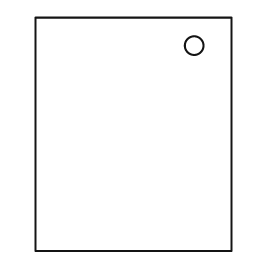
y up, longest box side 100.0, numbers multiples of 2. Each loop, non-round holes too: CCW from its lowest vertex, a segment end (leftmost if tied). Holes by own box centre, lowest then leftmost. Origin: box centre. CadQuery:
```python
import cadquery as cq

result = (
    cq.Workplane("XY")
    .moveTo(-42.0, -50.0)
    .lineTo(42.0, -50.0)
    .lineTo(42.0, 50.0)
    .lineTo(-42.0, 50.0)
    .close()
    .moveTo(26.0, 38.0)
    .circle(4.0)
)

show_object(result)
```